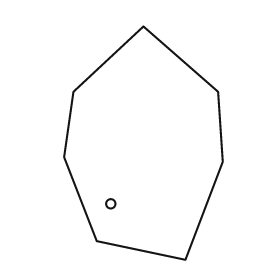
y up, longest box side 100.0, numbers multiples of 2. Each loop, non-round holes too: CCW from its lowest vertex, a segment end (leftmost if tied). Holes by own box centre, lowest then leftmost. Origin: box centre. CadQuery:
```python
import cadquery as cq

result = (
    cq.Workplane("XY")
    .moveTo(18.0, -50.0)
    .lineTo(34.0, -8.0)
    .lineTo(32.0, 22.0)
    .lineTo(0.0, 50.0)
    .lineTo(-30.0, 22.0)
    .lineTo(-34.0, -6.0)
    .lineTo(-20.0, -42.0)
    .close()
    .moveTo(-14.0, -26.0)
    .circle(2.0)
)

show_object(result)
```